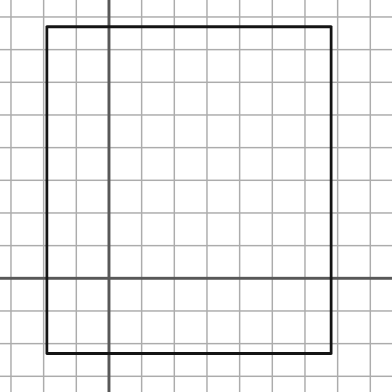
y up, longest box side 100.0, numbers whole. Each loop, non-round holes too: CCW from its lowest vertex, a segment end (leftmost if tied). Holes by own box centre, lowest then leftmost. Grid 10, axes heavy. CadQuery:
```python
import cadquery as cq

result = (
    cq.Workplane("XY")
    .moveTo(-19.0, -23.0)
    .lineTo(68.0, -23.0)
    .lineTo(68.0, 77.0)
    .lineTo(-19.0, 77.0)
    .close()
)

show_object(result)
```